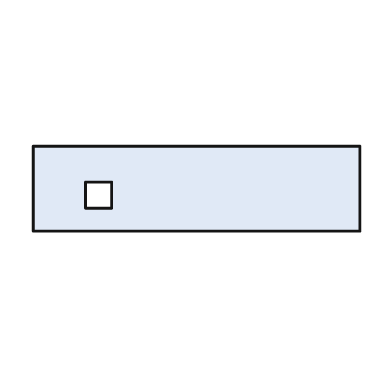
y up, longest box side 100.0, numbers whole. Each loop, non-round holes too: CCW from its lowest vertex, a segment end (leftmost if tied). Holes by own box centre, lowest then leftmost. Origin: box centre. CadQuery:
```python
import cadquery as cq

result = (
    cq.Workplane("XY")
    .moveTo(-50.0, -13.0)
    .lineTo(50.0, -13.0)
    .lineTo(50.0, 13.0)
    .lineTo(-50.0, 13.0)
    .close()
    .moveTo(-34.0, -6.0)
    .lineTo(-26.0, -6.0)
    .lineTo(-26.0, 2.0)
    .lineTo(-34.0, 2.0)
    .close()
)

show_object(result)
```